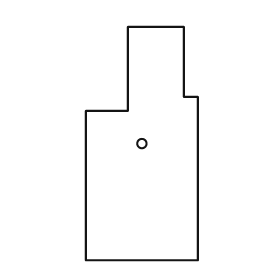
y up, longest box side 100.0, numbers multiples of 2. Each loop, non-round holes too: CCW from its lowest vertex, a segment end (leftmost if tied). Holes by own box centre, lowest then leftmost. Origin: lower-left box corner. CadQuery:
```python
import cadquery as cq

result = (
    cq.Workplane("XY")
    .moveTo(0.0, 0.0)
    .lineTo(48.0, 0.0)
    .lineTo(48.0, 70.0)
    .lineTo(42.0, 70.0)
    .lineTo(42.0, 100.0)
    .lineTo(18.0, 100.0)
    .lineTo(18.0, 64.0)
    .lineTo(0.0, 64.0)
    .close()
    .moveTo(24.0, 50.0)
    .circle(2.0)
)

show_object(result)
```